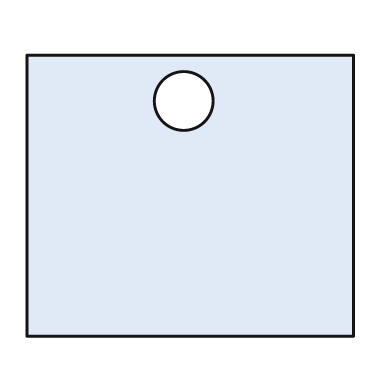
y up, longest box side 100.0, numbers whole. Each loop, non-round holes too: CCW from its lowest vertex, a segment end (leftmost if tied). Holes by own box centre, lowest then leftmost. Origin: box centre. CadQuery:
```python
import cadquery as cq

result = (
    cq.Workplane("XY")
    .moveTo(-50.0, -43.0)
    .lineTo(50.0, -43.0)
    .lineTo(50.0, 43.0)
    .lineTo(-50.0, 43.0)
    .close()
    .moveTo(-2.0, 29.0)
    .circle(9.0)
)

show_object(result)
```